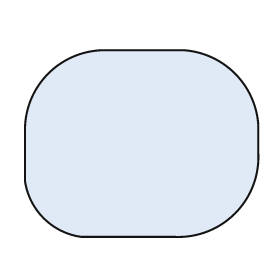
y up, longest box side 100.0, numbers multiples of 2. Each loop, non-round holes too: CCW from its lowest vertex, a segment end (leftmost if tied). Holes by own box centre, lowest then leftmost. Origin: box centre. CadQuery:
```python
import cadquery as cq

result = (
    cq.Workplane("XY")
    .moveTo(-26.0, -40.0)
    .lineTo(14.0, -40.0)
    .threePointArc((40.0, -30.0), (50.0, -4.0))
    .lineTo(50.0, 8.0)
    .threePointArc((40.0, 30.0), (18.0, 40.0))
    .lineTo(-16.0, 40.0)
    .threePointArc((-40.0, 30.0), (-50.0, 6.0))
    .lineTo(-50.0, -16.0)
    .threePointArc((-42.0, -32.0), (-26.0, -40.0))
    .close()
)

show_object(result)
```